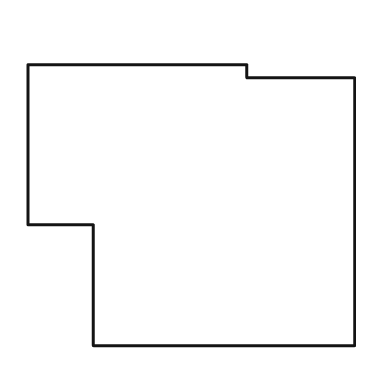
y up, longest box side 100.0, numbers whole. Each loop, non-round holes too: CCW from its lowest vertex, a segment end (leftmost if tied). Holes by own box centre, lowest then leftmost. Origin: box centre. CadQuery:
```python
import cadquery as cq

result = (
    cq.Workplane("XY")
    .moveTo(-30.0, -43.0)
    .lineTo(50.0, -43.0)
    .lineTo(50.0, 39.0)
    .lineTo(17.0, 39.0)
    .lineTo(17.0, 43.0)
    .lineTo(-50.0, 43.0)
    .lineTo(-50.0, -6.0)
    .lineTo(-30.0, -6.0)
    .close()
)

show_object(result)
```